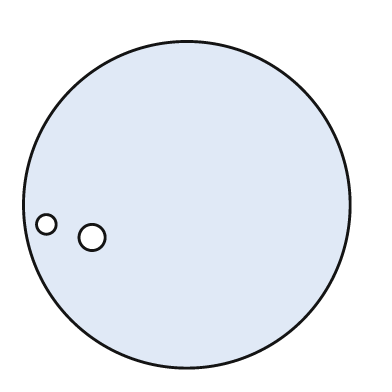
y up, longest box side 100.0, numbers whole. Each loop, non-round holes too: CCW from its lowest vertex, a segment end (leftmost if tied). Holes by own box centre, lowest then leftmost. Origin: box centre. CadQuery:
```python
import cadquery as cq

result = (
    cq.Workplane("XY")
    .moveTo(0.0, 0.0)
    .circle(50.0)
    .moveTo(-29.0, -10.0)
    .circle(4.0)
    .moveTo(-43.0, -6.0)
    .circle(3.0)
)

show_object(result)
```